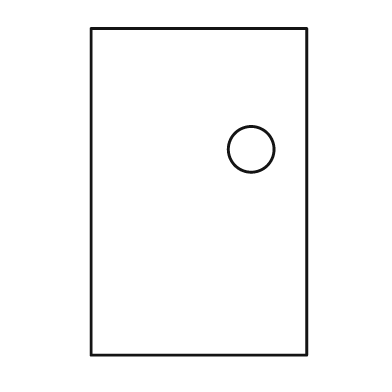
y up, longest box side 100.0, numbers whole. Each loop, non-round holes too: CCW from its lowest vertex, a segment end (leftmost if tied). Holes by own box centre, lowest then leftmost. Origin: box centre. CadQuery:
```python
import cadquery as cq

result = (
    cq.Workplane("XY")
    .moveTo(-33.0, -50.0)
    .lineTo(33.0, -50.0)
    .lineTo(33.0, 50.0)
    .lineTo(-33.0, 50.0)
    .close()
    .moveTo(16.0, 13.0)
    .circle(7.0)
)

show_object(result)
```